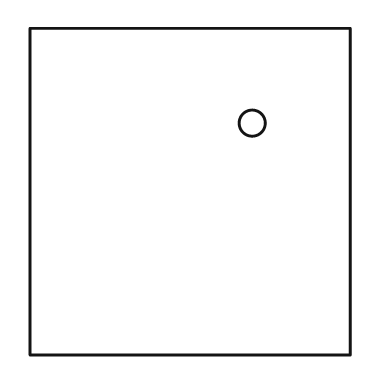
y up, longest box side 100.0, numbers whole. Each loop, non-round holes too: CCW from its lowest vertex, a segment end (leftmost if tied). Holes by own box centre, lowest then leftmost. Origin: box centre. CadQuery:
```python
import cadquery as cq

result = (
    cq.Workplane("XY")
    .moveTo(-49.0, -50.0)
    .lineTo(49.0, -50.0)
    .lineTo(49.0, 50.0)
    .lineTo(-49.0, 50.0)
    .close()
    .moveTo(19.0, 21.0)
    .circle(4.0)
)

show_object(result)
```